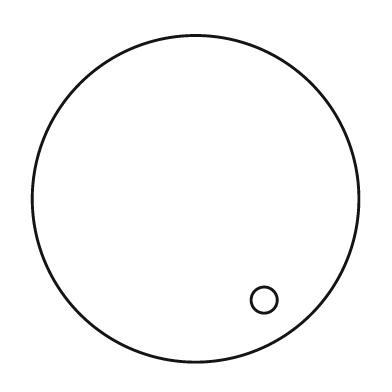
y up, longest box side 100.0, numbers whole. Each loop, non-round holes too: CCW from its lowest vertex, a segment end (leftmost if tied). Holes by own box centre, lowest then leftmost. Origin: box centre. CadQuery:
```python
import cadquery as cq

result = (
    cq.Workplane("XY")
    .moveTo(0.0, 0.0)
    .circle(50.0)
    .moveTo(21.0, -31.0)
    .circle(4.0)
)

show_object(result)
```